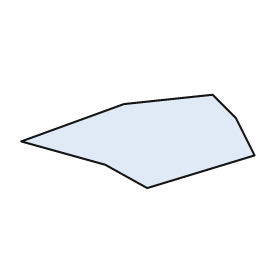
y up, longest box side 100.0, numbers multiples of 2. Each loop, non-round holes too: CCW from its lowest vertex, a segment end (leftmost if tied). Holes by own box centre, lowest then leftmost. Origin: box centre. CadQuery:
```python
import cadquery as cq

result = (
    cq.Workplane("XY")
    .moveTo(4.0, -20.0)
    .lineTo(50.0, -6.0)
    .lineTo(42.0, 10.0)
    .lineTo(32.0, 20.0)
    .lineTo(-6.0, 16.0)
    .lineTo(-50.0, 0.0)
    .lineTo(-14.0, -10.0)
    .close()
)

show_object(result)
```